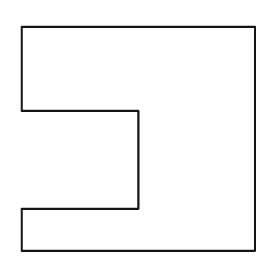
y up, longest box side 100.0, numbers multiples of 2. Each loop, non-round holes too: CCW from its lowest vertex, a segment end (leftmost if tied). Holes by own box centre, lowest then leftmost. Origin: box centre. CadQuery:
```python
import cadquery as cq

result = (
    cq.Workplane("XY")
    .moveTo(-50.0, -48.0)
    .lineTo(50.0, -48.0)
    .lineTo(50.0, 48.0)
    .lineTo(-50.0, 48.0)
    .lineTo(-50.0, 12.0)
    .lineTo(0.0, 12.0)
    .lineTo(0.0, -30.0)
    .lineTo(-50.0, -30.0)
    .close()
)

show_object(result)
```